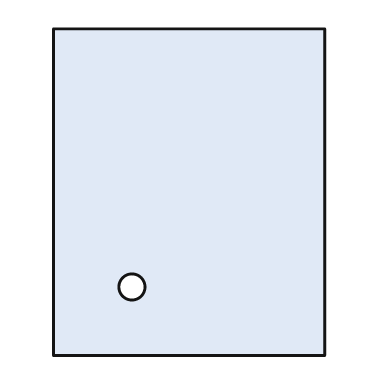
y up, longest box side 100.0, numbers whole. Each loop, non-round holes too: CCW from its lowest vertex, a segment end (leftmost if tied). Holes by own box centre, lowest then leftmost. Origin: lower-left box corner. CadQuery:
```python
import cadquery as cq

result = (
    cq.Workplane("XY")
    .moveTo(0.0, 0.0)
    .lineTo(83.0, 0.0)
    .lineTo(83.0, 100.0)
    .lineTo(0.0, 100.0)
    .close()
    .moveTo(24.0, 21.0)
    .circle(4.0)
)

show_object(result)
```